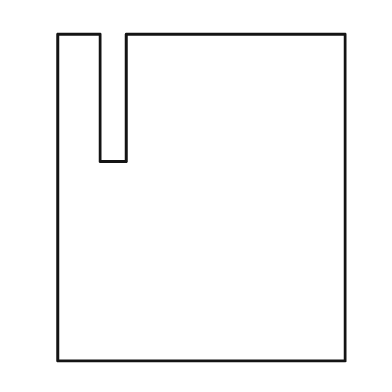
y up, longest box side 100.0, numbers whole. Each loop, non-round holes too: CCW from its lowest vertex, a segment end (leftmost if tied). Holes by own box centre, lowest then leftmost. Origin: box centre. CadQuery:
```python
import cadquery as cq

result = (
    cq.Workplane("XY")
    .moveTo(-44.0, -50.0)
    .lineTo(44.0, -50.0)
    .lineTo(44.0, 50.0)
    .lineTo(-23.0, 50.0)
    .lineTo(-23.0, 11.0)
    .lineTo(-31.0, 11.0)
    .lineTo(-31.0, 50.0)
    .lineTo(-44.0, 50.0)
    .close()
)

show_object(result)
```